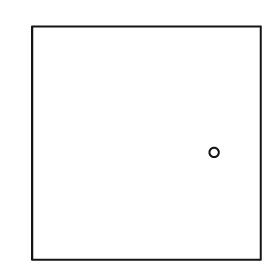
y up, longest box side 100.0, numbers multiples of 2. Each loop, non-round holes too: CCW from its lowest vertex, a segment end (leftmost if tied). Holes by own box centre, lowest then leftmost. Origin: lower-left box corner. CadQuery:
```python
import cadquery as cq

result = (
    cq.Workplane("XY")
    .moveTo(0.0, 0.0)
    .lineTo(98.0, 0.0)
    .lineTo(98.0, 100.0)
    .lineTo(0.0, 100.0)
    .close()
    .moveTo(78.0, 46.0)
    .circle(2.0)
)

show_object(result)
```